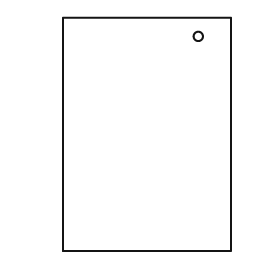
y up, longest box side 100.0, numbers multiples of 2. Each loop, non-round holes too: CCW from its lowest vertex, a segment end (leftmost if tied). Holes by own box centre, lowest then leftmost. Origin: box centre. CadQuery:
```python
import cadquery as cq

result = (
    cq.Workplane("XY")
    .moveTo(-36.0, -50.0)
    .lineTo(36.0, -50.0)
    .lineTo(36.0, 50.0)
    .lineTo(-36.0, 50.0)
    .close()
    .moveTo(22.0, 42.0)
    .circle(2.0)
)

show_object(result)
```